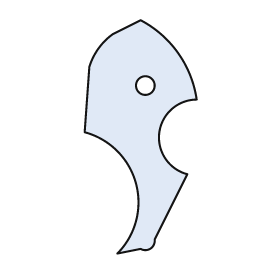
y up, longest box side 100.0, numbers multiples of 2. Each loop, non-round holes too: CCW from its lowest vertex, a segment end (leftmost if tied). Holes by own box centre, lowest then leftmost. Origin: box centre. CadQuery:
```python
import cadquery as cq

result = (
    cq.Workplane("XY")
    .moveTo(-10.0, -50.0)
    .lineTo(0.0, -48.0)
    .threePointArc((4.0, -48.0), (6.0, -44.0))
    .lineTo(20.0, -16.0)
    .threePointArc((8.0, 2.0), (24.0, 16.0))
    .threePointArc((16.0, 36.0), (0.0, 50.0))
    .lineTo(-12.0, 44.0)
    .threePointArc((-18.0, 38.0), (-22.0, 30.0))
    .lineTo(-24.0, 2.0)
    .threePointArc((-2.0, -20.0), (-10.0, -50.0))
    .close()
    .moveTo(2.0, 22.0)
    .circle(4.0)
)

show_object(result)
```